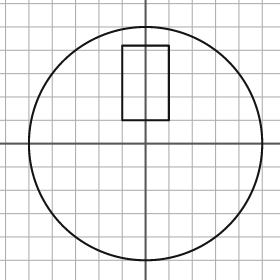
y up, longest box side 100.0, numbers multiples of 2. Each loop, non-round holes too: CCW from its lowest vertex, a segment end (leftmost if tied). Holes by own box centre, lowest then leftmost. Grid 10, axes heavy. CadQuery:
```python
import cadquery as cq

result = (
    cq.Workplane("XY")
    .moveTo(0.0, 0.0)
    .circle(50.0)
    .moveTo(-10.0, 10.0)
    .lineTo(10.0, 10.0)
    .lineTo(10.0, 42.0)
    .lineTo(-10.0, 42.0)
    .close()
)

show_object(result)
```